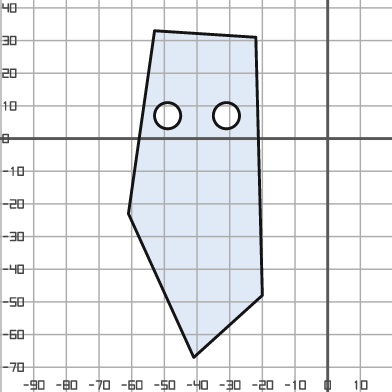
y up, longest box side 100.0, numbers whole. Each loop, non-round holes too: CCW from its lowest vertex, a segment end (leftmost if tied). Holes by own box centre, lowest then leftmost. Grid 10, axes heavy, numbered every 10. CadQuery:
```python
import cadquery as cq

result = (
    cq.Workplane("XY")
    .moveTo(-41.0, -67.0)
    .lineTo(-20.0, -48.0)
    .lineTo(-22.0, 31.0)
    .lineTo(-53.0, 33.0)
    .lineTo(-61.0, -23.0)
    .close()
    .moveTo(-49.0, 7.0)
    .circle(4.0)
    .moveTo(-31.0, 7.0)
    .circle(4.0)
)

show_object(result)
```